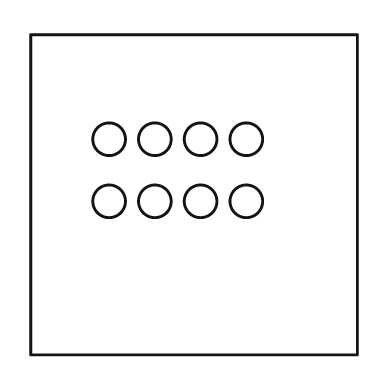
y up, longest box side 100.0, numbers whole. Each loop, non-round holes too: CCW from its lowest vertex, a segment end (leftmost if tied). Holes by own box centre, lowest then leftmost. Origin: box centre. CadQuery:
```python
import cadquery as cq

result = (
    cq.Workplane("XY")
    .moveTo(-50.0, -49.0)
    .lineTo(50.0, -49.0)
    .lineTo(50.0, 49.0)
    .lineTo(-50.0, 49.0)
    .close()
    .moveTo(-26.0, -2.0)
    .circle(5.0)
    .moveTo(-12.0, -2.0)
    .circle(5.0)
    .moveTo(2.0, -2.0)
    .circle(5.0)
    .moveTo(16.0, -2.0)
    .circle(5.0)
    .moveTo(-26.0, 17.0)
    .circle(5.0)
    .moveTo(-12.0, 17.0)
    .circle(5.0)
    .moveTo(2.0, 17.0)
    .circle(5.0)
    .moveTo(16.0, 17.0)
    .circle(5.0)
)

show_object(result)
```